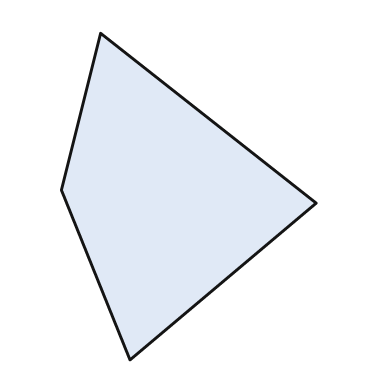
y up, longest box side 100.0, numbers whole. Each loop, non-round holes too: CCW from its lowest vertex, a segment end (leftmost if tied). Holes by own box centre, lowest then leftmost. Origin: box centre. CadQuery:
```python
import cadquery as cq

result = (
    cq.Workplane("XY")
    .moveTo(-18.0, -50.0)
    .lineTo(39.0, -2.0)
    .lineTo(-27.0, 50.0)
    .lineTo(-39.0, 2.0)
    .close()
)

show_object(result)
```